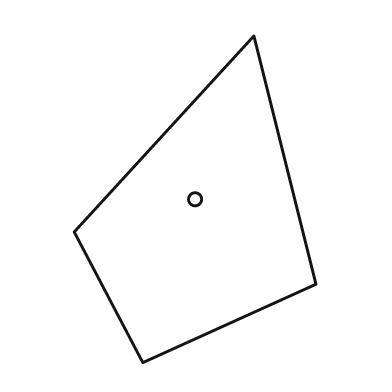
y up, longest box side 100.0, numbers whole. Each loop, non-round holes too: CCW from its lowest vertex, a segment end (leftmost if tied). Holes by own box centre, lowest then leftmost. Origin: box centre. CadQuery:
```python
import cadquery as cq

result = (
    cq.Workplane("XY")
    .moveTo(-16.0, -50.0)
    .lineTo(37.0, -26.0)
    .lineTo(18.0, 50.0)
    .lineTo(-37.0, -10.0)
    .close()
    .moveTo(0.0, 0.0)
    .circle(2.0)
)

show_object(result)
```